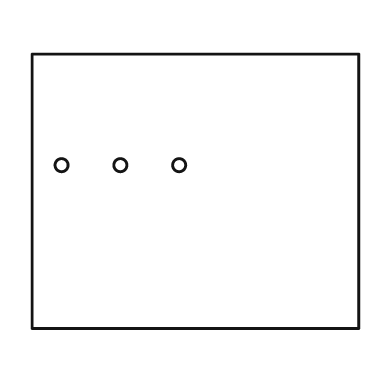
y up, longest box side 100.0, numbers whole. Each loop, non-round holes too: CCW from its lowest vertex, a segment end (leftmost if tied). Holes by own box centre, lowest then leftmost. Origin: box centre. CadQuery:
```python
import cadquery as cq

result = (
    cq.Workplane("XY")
    .moveTo(-50.0, -42.0)
    .lineTo(50.0, -42.0)
    .lineTo(50.0, 42.0)
    .lineTo(-50.0, 42.0)
    .close()
    .moveTo(-41.0, 8.0)
    .circle(2.0)
    .moveTo(-23.0, 8.0)
    .circle(2.0)
    .moveTo(-5.0, 8.0)
    .circle(2.0)
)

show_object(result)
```